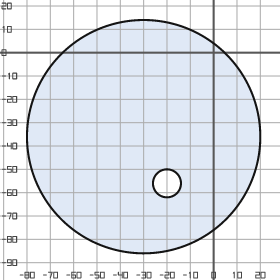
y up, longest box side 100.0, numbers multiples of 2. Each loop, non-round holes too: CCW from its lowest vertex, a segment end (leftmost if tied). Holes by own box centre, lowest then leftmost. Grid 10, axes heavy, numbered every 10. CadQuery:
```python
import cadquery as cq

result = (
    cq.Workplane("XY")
    .moveTo(-30.0, -36.0)
    .circle(50.0)
    .moveTo(-20.0, -56.0)
    .circle(6.0)
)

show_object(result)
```